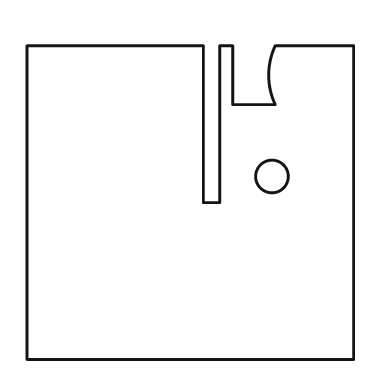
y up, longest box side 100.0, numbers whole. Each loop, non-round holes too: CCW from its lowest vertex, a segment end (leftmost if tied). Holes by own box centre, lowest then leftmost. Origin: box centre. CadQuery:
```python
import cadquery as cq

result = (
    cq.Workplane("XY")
    .moveTo(-50.0, -48.0)
    .lineTo(50.0, -48.0)
    .lineTo(50.0, 48.0)
    .lineTo(26.0, 48.0)
    .threePointArc((24.0, 39.0), (26.0, 30.0))
    .lineTo(13.0, 30.0)
    .lineTo(13.0, 48.0)
    .lineTo(9.0, 48.0)
    .lineTo(9.0, 0.0)
    .lineTo(4.0, 0.0)
    .lineTo(4.0, 48.0)
    .lineTo(-50.0, 48.0)
    .close()
    .moveTo(25.0, 8.0)
    .circle(5.0)
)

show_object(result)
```